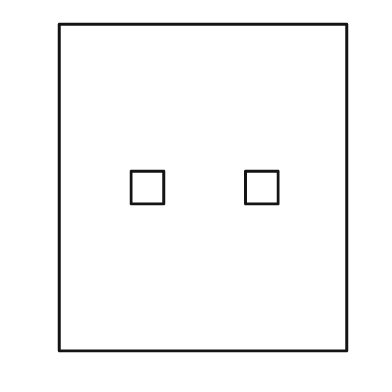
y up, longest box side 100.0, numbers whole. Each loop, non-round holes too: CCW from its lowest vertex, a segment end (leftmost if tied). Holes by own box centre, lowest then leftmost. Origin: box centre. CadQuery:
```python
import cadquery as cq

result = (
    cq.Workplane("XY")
    .moveTo(-44.0, -50.0)
    .lineTo(44.0, -50.0)
    .lineTo(44.0, 50.0)
    .lineTo(-44.0, 50.0)
    .close()
    .moveTo(-22.0, -5.0)
    .lineTo(-12.0, -5.0)
    .lineTo(-12.0, 5.0)
    .lineTo(-22.0, 5.0)
    .close()
    .moveTo(13.0, -5.0)
    .lineTo(23.0, -5.0)
    .lineTo(23.0, 5.0)
    .lineTo(13.0, 5.0)
    .close()
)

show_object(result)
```